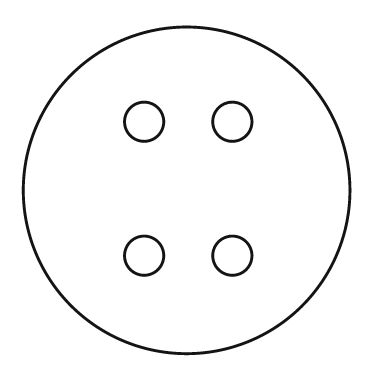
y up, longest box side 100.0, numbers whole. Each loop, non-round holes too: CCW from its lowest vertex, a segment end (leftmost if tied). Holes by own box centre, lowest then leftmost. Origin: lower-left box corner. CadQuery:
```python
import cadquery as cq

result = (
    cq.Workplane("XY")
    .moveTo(50.0, 50.0)
    .circle(50.0)
    .moveTo(37.0, 30.0)
    .circle(6.0)
    .moveTo(64.0, 30.0)
    .circle(6.0)
    .moveTo(37.0, 71.0)
    .circle(6.0)
    .moveTo(64.0, 71.0)
    .circle(6.0)
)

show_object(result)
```